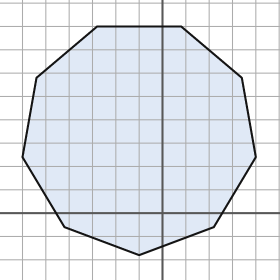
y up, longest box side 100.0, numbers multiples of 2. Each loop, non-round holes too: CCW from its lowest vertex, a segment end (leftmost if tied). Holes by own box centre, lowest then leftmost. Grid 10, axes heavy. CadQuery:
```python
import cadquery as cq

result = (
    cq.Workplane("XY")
    .moveTo(-10.0, -18.0)
    .lineTo(22.0, -6.0)
    .lineTo(40.0, 24.0)
    .lineTo(34.0, 58.0)
    .lineTo(8.0, 80.0)
    .lineTo(-28.0, 80.0)
    .lineTo(-54.0, 58.0)
    .lineTo(-60.0, 24.0)
    .lineTo(-42.0, -6.0)
    .close()
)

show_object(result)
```